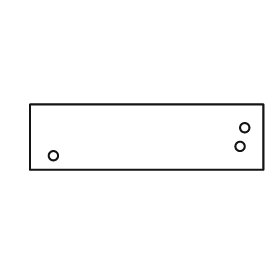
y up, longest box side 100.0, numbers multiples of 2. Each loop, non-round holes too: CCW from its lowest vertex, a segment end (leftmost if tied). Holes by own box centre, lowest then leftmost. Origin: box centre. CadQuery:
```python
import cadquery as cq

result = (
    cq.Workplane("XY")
    .moveTo(-50.0, -14.0)
    .lineTo(50.0, -14.0)
    .lineTo(50.0, 14.0)
    .lineTo(-50.0, 14.0)
    .close()
    .moveTo(-40.0, -8.0)
    .circle(2.0)
    .moveTo(40.0, -4.0)
    .circle(2.0)
    .moveTo(42.0, 4.0)
    .circle(2.0)
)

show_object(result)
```